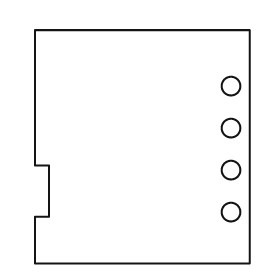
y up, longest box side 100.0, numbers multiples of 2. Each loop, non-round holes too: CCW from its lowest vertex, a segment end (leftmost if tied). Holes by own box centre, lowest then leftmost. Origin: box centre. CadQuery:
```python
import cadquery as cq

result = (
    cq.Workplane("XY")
    .moveTo(-46.0, -50.0)
    .lineTo(46.0, -50.0)
    .lineTo(46.0, 50.0)
    .lineTo(-46.0, 50.0)
    .lineTo(-46.0, -8.0)
    .lineTo(-40.0, -8.0)
    .lineTo(-40.0, -30.0)
    .lineTo(-46.0, -30.0)
    .close()
    .moveTo(38.0, -28.0)
    .circle(4.0)
    .moveTo(38.0, -10.0)
    .circle(4.0)
    .moveTo(38.0, 8.0)
    .circle(4.0)
    .moveTo(38.0, 26.0)
    .circle(4.0)
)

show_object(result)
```